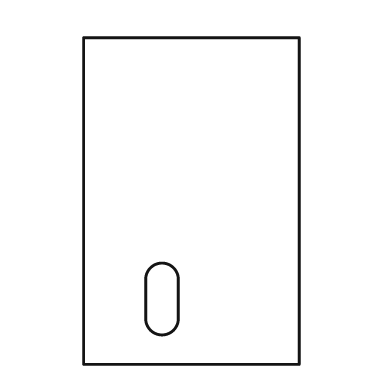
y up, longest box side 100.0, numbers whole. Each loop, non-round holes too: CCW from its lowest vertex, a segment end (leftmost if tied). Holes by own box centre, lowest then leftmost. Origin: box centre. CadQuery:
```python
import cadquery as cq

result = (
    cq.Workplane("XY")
    .moveTo(-33.0, -50.0)
    .lineTo(33.0, -50.0)
    .lineTo(33.0, 50.0)
    .lineTo(-33.0, 50.0)
    .close()
    .moveTo(-14.0, -36.0)
    .threePointArc((-9.0, -41.0), (-4.0, -36.0))
    .lineTo(-4.0, -24.0)
    .threePointArc((-9.0, -19.0), (-14.0, -24.0))
    .close()
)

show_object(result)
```